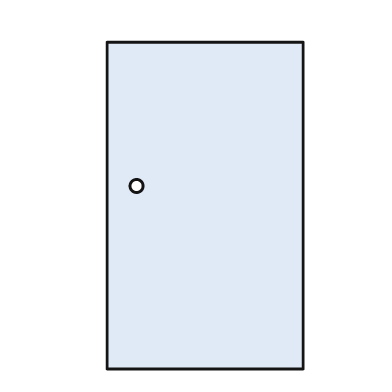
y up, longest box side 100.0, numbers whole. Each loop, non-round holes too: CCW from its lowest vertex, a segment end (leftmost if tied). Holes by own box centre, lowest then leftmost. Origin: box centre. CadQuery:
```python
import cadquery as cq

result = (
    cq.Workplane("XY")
    .moveTo(-30.0, -50.0)
    .lineTo(30.0, -50.0)
    .lineTo(30.0, 50.0)
    .lineTo(-30.0, 50.0)
    .close()
    .moveTo(-21.0, 6.0)
    .circle(2.0)
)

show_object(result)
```